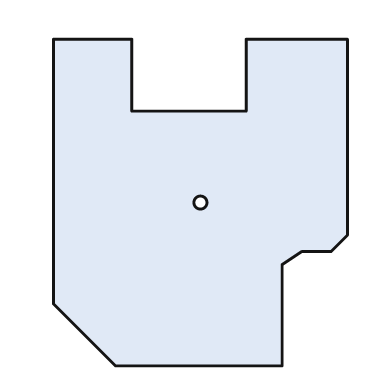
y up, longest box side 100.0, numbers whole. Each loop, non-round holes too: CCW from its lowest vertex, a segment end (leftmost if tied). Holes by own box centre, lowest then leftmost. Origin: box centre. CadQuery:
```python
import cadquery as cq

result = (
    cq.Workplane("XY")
    .moveTo(-26.0, -50.0)
    .lineTo(25.0, -50.0)
    .lineTo(25.0, -19.0)
    .lineTo(31.0, -15.0)
    .lineTo(40.0, -15.0)
    .lineTo(45.0, -10.0)
    .lineTo(45.0, 50.0)
    .lineTo(14.0, 50.0)
    .lineTo(14.0, 28.0)
    .lineTo(-21.0, 28.0)
    .lineTo(-21.0, 50.0)
    .lineTo(-45.0, 50.0)
    .lineTo(-45.0, -31.0)
    .close()
    .moveTo(0.0, 0.0)
    .circle(2.0)
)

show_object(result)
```